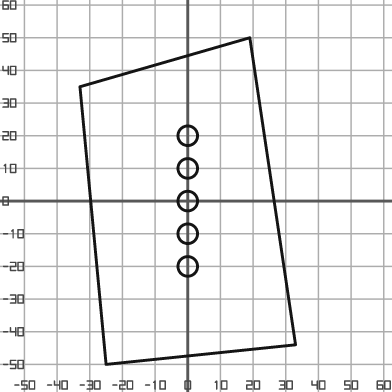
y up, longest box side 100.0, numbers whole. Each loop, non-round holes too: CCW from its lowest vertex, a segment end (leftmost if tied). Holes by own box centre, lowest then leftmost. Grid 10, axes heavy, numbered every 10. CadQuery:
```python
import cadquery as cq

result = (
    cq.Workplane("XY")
    .moveTo(-25.0, -50.0)
    .lineTo(33.0, -44.0)
    .lineTo(19.0, 50.0)
    .lineTo(-33.0, 35.0)
    .close()
    .moveTo(0.0, -20.0)
    .circle(3.0)
    .moveTo(0.0, -10.0)
    .circle(3.0)
    .moveTo(0.0, 0.0)
    .circle(3.0)
    .moveTo(0.0, 10.0)
    .circle(3.0)
    .moveTo(0.0, 20.0)
    .circle(3.0)
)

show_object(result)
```